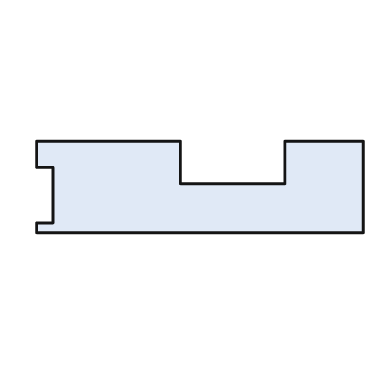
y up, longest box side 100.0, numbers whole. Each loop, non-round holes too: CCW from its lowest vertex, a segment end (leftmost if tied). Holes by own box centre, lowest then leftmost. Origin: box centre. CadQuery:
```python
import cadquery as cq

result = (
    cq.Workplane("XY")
    .moveTo(-50.0, -14.0)
    .lineTo(50.0, -14.0)
    .lineTo(50.0, 14.0)
    .lineTo(26.0, 14.0)
    .lineTo(26.0, 1.0)
    .lineTo(-6.0, 1.0)
    .lineTo(-6.0, 14.0)
    .lineTo(-50.0, 14.0)
    .lineTo(-50.0, 6.0)
    .lineTo(-45.0, 6.0)
    .lineTo(-45.0, -11.0)
    .lineTo(-50.0, -11.0)
    .close()
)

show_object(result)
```